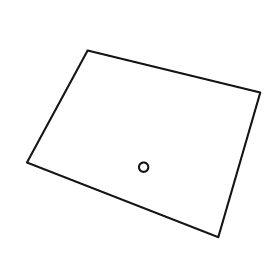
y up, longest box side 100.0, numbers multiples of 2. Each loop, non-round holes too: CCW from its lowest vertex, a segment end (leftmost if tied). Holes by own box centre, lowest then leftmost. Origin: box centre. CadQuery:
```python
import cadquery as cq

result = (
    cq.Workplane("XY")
    .moveTo(32.0, -40.0)
    .lineTo(50.0, 22.0)
    .lineTo(-24.0, 40.0)
    .lineTo(-50.0, -8.0)
    .close()
    .moveTo(0.0, -10.0)
    .circle(2.0)
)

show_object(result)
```